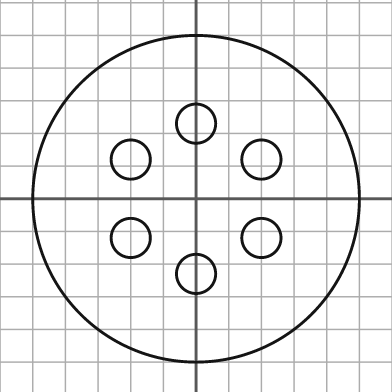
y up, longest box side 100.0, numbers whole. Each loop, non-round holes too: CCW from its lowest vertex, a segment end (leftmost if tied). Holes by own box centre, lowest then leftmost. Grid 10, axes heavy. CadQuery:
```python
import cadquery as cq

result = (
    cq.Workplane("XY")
    .moveTo(0.0, 0.0)
    .circle(50.0)
    .moveTo(0.0, -23.0)
    .circle(6.0)
    .moveTo(-20.0, -12.0)
    .circle(6.0)
    .moveTo(20.0, -12.0)
    .circle(6.0)
    .moveTo(-20.0, 12.0)
    .circle(6.0)
    .moveTo(20.0, 12.0)
    .circle(6.0)
    .moveTo(0.0, 23.0)
    .circle(6.0)
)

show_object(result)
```